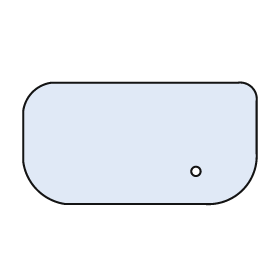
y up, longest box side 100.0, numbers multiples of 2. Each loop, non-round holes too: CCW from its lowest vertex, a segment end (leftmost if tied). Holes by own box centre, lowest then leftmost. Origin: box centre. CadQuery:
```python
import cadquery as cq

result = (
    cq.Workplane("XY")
    .moveTo(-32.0, -26.0)
    .lineTo(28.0, -26.0)
    .threePointArc((44.0, -20.0), (50.0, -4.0))
    .lineTo(50.0, 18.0)
    .threePointArc((48.0, 24.0), (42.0, 26.0))
    .lineTo(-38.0, 26.0)
    .threePointArc((-46.0, 22.0), (-50.0, 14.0))
    .lineTo(-50.0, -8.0)
    .threePointArc((-44.0, -20.0), (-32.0, -26.0))
    .close()
    .moveTo(24.0, -12.0)
    .circle(2.0)
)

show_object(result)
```